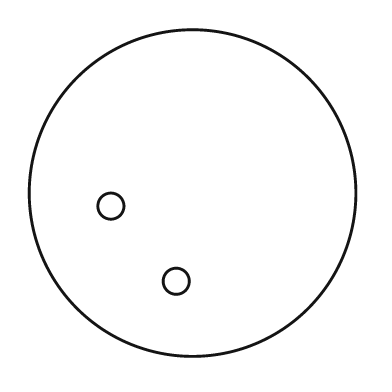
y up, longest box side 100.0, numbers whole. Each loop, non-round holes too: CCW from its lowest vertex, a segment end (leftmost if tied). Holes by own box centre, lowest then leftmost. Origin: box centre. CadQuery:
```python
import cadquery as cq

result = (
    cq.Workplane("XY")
    .moveTo(0.0, 0.0)
    .circle(50.0)
    .moveTo(-5.0, -27.0)
    .circle(4.0)
    .moveTo(-25.0, -4.0)
    .circle(4.0)
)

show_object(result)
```